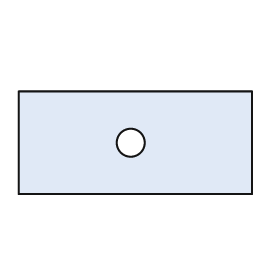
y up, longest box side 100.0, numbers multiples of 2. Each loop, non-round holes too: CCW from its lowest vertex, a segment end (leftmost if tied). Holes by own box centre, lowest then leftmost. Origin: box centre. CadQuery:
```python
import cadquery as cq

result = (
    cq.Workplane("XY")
    .moveTo(-50.0, -22.0)
    .lineTo(50.0, -22.0)
    .lineTo(50.0, 22.0)
    .lineTo(-50.0, 22.0)
    .close()
    .moveTo(-2.0, 0.0)
    .circle(6.0)
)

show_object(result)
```